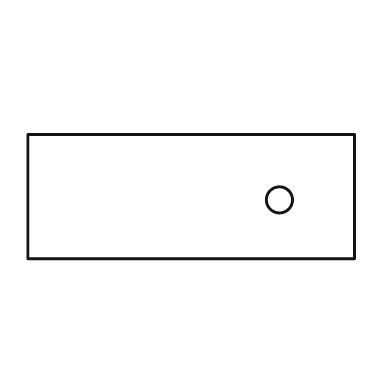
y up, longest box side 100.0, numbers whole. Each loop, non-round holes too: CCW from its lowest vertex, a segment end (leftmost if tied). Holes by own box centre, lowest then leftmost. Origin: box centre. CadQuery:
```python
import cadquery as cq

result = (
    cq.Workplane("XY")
    .moveTo(-50.0, -19.0)
    .lineTo(50.0, -19.0)
    .lineTo(50.0, 19.0)
    .lineTo(-50.0, 19.0)
    .close()
    .moveTo(27.0, -1.0)
    .circle(4.0)
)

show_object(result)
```